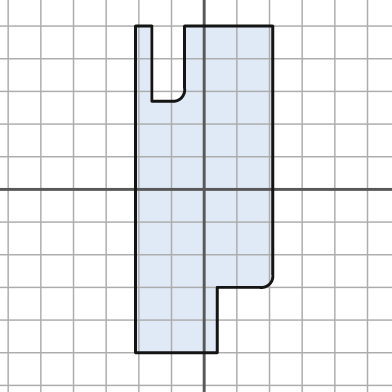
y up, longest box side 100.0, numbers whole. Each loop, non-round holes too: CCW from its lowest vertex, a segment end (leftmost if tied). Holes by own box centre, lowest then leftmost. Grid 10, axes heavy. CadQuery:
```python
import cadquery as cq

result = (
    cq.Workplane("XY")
    .moveTo(-21.0, -50.0)
    .lineTo(4.0, -50.0)
    .lineTo(4.0, -30.0)
    .lineTo(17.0, -30.0)
    .threePointArc((20.0, -29.0), (21.0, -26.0))
    .lineTo(21.0, 50.0)
    .lineTo(-6.0, 50.0)
    .lineTo(-6.0, 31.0)
    .threePointArc((-7.0, 28.0), (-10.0, 27.0))
    .lineTo(-16.0, 27.0)
    .lineTo(-16.0, 50.0)
    .lineTo(-21.0, 50.0)
    .close()
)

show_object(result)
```